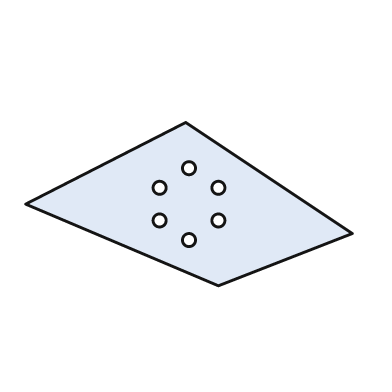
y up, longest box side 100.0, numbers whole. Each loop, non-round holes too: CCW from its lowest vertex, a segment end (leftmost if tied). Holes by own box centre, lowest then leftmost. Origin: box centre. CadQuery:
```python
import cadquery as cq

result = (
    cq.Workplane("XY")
    .moveTo(9.0, -25.0)
    .lineTo(50.0, -9.0)
    .lineTo(-1.0, 25.0)
    .lineTo(-50.0, 0.0)
    .close()
    .moveTo(0.0, -11.0)
    .circle(2.0)
    .moveTo(-9.0, -5.0)
    .circle(2.0)
    .moveTo(9.0, -5.0)
    .circle(2.0)
    .moveTo(-9.0, 5.0)
    .circle(2.0)
    .moveTo(9.0, 5.0)
    .circle(2.0)
    .moveTo(0.0, 11.0)
    .circle(2.0)
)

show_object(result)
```